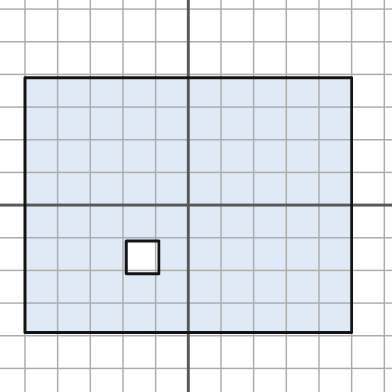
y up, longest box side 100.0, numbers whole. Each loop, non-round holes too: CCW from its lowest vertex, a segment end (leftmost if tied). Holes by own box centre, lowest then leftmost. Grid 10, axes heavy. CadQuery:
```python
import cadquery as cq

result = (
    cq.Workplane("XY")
    .moveTo(-50.0, -39.0)
    .lineTo(50.0, -39.0)
    .lineTo(50.0, 39.0)
    .lineTo(-50.0, 39.0)
    .close()
    .moveTo(-19.0, -21.0)
    .lineTo(-9.0, -21.0)
    .lineTo(-9.0, -11.0)
    .lineTo(-19.0, -11.0)
    .close()
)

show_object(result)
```